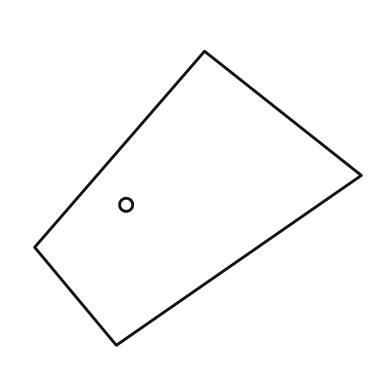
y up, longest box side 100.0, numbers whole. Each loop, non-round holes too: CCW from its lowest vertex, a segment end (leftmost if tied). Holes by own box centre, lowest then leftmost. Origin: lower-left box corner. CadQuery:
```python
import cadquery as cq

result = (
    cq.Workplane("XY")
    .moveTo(25.0, 0.0)
    .lineTo(100.0, 52.0)
    .lineTo(52.0, 90.0)
    .lineTo(0.0, 30.0)
    .close()
    .moveTo(28.0, 43.0)
    .circle(2.0)
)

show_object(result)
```